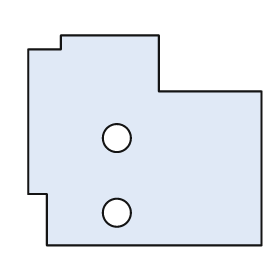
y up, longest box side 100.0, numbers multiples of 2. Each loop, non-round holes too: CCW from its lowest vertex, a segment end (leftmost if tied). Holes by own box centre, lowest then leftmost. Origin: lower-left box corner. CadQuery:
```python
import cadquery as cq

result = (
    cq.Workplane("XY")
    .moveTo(8.0, 0.0)
    .lineTo(100.0, 0.0)
    .lineTo(100.0, 66.0)
    .lineTo(56.0, 66.0)
    .lineTo(56.0, 90.0)
    .lineTo(14.0, 90.0)
    .lineTo(14.0, 84.0)
    .lineTo(0.0, 84.0)
    .lineTo(0.0, 22.0)
    .lineTo(8.0, 22.0)
    .close()
    .moveTo(38.0, 14.0)
    .circle(6.0)
    .moveTo(38.0, 46.0)
    .circle(6.0)
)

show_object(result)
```